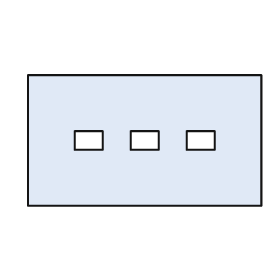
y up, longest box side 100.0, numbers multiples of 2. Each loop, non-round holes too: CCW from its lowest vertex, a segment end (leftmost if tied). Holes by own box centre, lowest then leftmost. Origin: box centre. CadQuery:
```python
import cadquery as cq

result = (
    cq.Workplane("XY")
    .moveTo(-50.0, -28.0)
    .lineTo(50.0, -28.0)
    .lineTo(50.0, 28.0)
    .lineTo(-50.0, 28.0)
    .close()
    .moveTo(-30.0, -4.0)
    .lineTo(-18.0, -4.0)
    .lineTo(-18.0, 4.0)
    .lineTo(-30.0, 4.0)
    .close()
    .moveTo(-6.0, -4.0)
    .lineTo(6.0, -4.0)
    .lineTo(6.0, 4.0)
    .lineTo(-6.0, 4.0)
    .close()
    .moveTo(18.0, -4.0)
    .lineTo(30.0, -4.0)
    .lineTo(30.0, 4.0)
    .lineTo(18.0, 4.0)
    .close()
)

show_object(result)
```